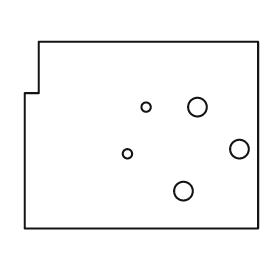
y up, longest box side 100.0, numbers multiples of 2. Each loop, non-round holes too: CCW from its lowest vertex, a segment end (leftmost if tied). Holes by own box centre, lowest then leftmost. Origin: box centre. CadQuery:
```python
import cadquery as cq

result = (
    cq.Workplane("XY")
    .moveTo(-50.0, -40.0)
    .lineTo(50.0, -40.0)
    .lineTo(50.0, 40.0)
    .lineTo(-44.0, 40.0)
    .lineTo(-44.0, 18.0)
    .lineTo(-50.0, 18.0)
    .close()
    .moveTo(18.0, -24.0)
    .circle(4.0)
    .moveTo(-6.0, -8.0)
    .circle(2.0)
    .moveTo(42.0, -6.0)
    .circle(4.0)
    .moveTo(2.0, 12.0)
    .circle(2.0)
    .moveTo(24.0, 12.0)
    .circle(4.0)
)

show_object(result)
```